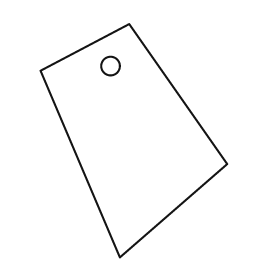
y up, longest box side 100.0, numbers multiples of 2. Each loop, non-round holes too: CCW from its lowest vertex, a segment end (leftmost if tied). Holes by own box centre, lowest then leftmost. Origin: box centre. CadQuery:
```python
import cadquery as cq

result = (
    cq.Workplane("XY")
    .moveTo(-6.0, -50.0)
    .lineTo(40.0, -10.0)
    .lineTo(-2.0, 50.0)
    .lineTo(-40.0, 30.0)
    .close()
    .moveTo(-10.0, 32.0)
    .circle(4.0)
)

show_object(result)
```